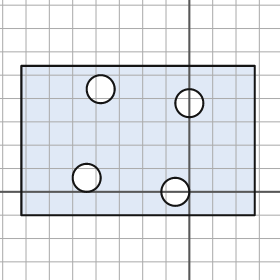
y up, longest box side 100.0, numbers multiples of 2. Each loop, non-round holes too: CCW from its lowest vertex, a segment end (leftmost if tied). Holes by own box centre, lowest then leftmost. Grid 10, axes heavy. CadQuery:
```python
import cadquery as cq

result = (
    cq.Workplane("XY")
    .moveTo(-72.0, -10.0)
    .lineTo(28.0, -10.0)
    .lineTo(28.0, 54.0)
    .lineTo(-72.0, 54.0)
    .close()
    .moveTo(-6.0, 0.0)
    .circle(6.0)
    .moveTo(-44.0, 6.0)
    .circle(6.0)
    .moveTo(0.0, 38.0)
    .circle(6.0)
    .moveTo(-38.0, 44.0)
    .circle(6.0)
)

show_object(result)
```